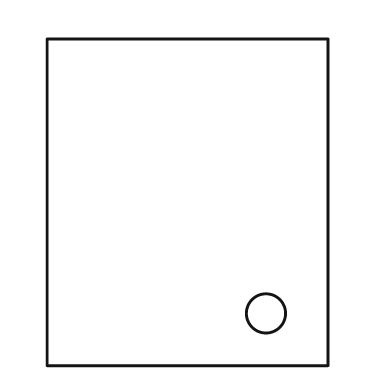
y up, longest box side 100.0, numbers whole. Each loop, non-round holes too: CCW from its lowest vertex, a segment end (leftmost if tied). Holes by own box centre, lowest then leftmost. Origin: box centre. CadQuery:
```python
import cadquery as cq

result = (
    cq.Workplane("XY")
    .moveTo(-43.0, -50.0)
    .lineTo(43.0, -50.0)
    .lineTo(43.0, 50.0)
    .lineTo(-43.0, 50.0)
    .close()
    .moveTo(24.0, -34.0)
    .circle(6.0)
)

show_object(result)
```